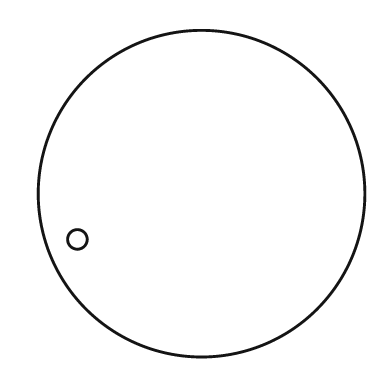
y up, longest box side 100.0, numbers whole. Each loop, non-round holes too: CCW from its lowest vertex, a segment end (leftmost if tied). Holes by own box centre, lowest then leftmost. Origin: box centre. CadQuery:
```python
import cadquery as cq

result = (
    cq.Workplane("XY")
    .moveTo(0.0, 0.0)
    .circle(50.0)
    .moveTo(-38.0, -14.0)
    .circle(3.0)
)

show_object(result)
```